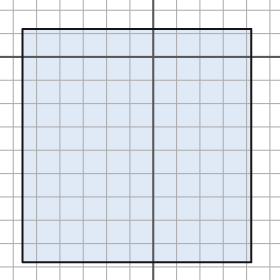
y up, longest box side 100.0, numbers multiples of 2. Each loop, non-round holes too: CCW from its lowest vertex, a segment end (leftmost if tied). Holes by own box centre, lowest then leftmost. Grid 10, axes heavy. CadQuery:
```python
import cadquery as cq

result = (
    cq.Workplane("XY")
    .moveTo(-56.0, -88.0)
    .lineTo(42.0, -88.0)
    .lineTo(42.0, 12.0)
    .lineTo(-56.0, 12.0)
    .close()
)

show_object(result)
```